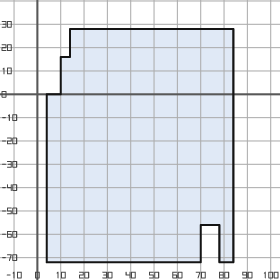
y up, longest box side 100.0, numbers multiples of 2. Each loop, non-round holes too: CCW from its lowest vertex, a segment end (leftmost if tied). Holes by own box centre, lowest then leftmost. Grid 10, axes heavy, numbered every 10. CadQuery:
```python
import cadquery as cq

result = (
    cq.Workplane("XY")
    .moveTo(4.0, -72.0)
    .lineTo(70.0, -72.0)
    .lineTo(70.0, -56.0)
    .lineTo(78.0, -56.0)
    .lineTo(78.0, -72.0)
    .lineTo(84.0, -72.0)
    .lineTo(84.0, 28.0)
    .lineTo(14.0, 28.0)
    .lineTo(14.0, 16.0)
    .lineTo(10.0, 16.0)
    .lineTo(10.0, 0.0)
    .lineTo(4.0, 0.0)
    .close()
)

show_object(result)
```